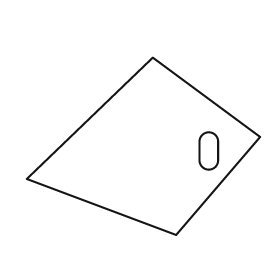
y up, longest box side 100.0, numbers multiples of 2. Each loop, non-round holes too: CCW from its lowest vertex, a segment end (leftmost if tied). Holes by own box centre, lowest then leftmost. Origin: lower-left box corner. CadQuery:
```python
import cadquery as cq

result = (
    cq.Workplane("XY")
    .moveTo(64.0, 0.0)
    .lineTo(100.0, 42.0)
    .lineTo(54.0, 76.0)
    .lineTo(0.0, 24.0)
    .close()
    .moveTo(74.0, 32.0)
    .threePointArc((78.0, 28.0), (82.0, 32.0))
    .lineTo(82.0, 40.0)
    .threePointArc((78.0, 44.0), (74.0, 40.0))
    .close()
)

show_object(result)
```